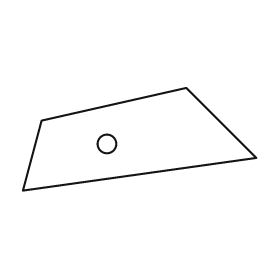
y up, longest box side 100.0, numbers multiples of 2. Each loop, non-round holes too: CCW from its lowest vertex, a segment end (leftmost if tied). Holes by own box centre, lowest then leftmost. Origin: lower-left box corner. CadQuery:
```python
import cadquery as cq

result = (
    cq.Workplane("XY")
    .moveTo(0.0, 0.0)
    .lineTo(100.0, 14.0)
    .lineTo(70.0, 44.0)
    .lineTo(8.0, 30.0)
    .close()
    .moveTo(36.0, 20.0)
    .circle(4.0)
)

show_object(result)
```